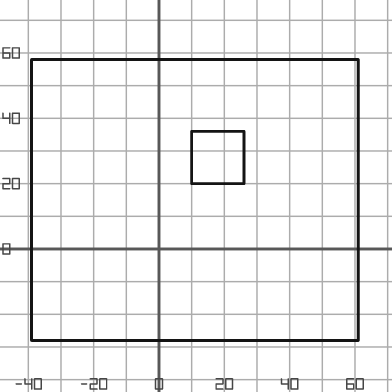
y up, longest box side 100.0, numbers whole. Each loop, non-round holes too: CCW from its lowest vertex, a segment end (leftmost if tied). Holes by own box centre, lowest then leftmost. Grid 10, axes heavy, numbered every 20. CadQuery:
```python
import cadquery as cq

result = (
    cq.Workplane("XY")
    .moveTo(-39.0, -28.0)
    .lineTo(61.0, -28.0)
    .lineTo(61.0, 58.0)
    .lineTo(-39.0, 58.0)
    .close()
    .moveTo(10.0, 20.0)
    .lineTo(26.0, 20.0)
    .lineTo(26.0, 36.0)
    .lineTo(10.0, 36.0)
    .close()
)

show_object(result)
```